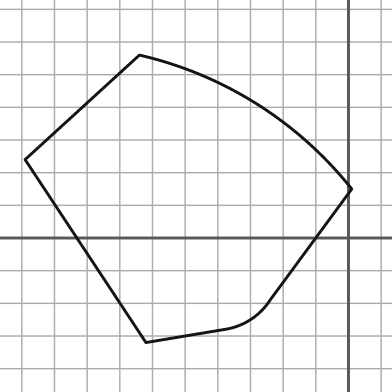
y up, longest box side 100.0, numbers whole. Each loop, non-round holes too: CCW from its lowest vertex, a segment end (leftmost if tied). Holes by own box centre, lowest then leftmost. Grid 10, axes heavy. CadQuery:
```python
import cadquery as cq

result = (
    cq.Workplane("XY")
    .moveTo(-62.0, -32.0)
    .lineTo(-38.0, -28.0)
    .threePointArc((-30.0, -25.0), (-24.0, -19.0))
    .lineTo(1.0, 15.0)
    .threePointArc((-28.0, 41.0), (-64.0, 56.0))
    .lineTo(-99.0, 24.0)
    .close()
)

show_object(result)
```